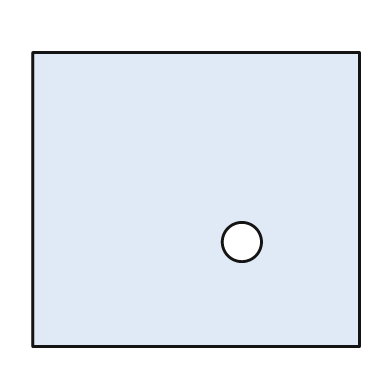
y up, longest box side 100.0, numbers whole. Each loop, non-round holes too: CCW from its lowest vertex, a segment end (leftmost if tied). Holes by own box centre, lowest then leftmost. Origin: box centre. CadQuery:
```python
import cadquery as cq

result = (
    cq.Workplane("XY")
    .moveTo(-50.0, -45.0)
    .lineTo(50.0, -45.0)
    .lineTo(50.0, 45.0)
    .lineTo(-50.0, 45.0)
    .close()
    .moveTo(14.0, -13.0)
    .circle(6.0)
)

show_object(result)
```